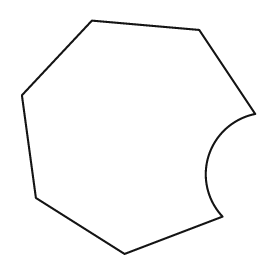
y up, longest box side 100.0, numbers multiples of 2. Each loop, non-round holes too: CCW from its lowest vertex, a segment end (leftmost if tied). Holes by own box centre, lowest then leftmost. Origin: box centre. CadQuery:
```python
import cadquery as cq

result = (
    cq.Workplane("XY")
    .moveTo(-6.0, -50.0)
    .lineTo(36.0, -34.0)
    .threePointArc((30.0, -8.0), (50.0, 10.0))
    .lineTo(26.0, 46.0)
    .lineTo(-20.0, 50.0)
    .lineTo(-50.0, 18.0)
    .lineTo(-44.0, -26.0)
    .close()
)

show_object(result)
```